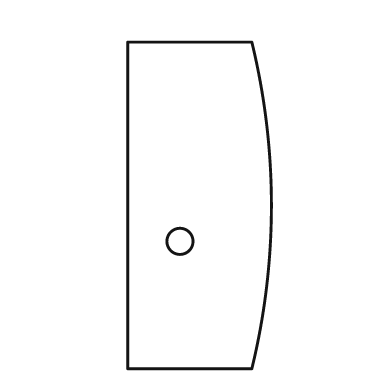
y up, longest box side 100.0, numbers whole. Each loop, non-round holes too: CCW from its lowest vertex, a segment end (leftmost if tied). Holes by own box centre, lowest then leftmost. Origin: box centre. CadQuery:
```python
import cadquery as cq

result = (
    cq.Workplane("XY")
    .moveTo(-22.0, -50.0)
    .lineTo(16.0, -50.0)
    .threePointArc((22.0, 0.0), (16.0, 50.0))
    .lineTo(-22.0, 50.0)
    .close()
    .moveTo(-6.0, -11.0)
    .circle(4.0)
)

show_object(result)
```